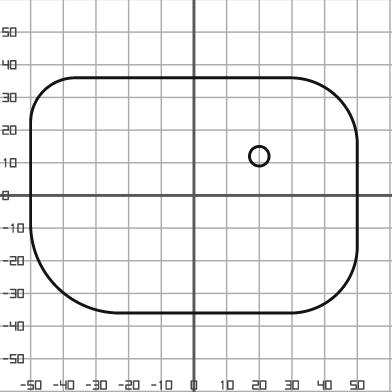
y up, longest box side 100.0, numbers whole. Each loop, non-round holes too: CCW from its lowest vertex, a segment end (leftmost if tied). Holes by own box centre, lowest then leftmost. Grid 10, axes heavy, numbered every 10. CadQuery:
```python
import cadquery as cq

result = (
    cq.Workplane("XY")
    .moveTo(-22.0, -36.0)
    .lineTo(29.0, -36.0)
    .threePointArc((44.0, -30.0), (50.0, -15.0))
    .lineTo(50.0, 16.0)
    .threePointArc((44.0, 30.0), (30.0, 36.0))
    .lineTo(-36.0, 36.0)
    .threePointArc((-46.0, 32.0), (-50.0, 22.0))
    .lineTo(-50.0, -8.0)
    .threePointArc((-42.0, -28.0), (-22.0, -36.0))
    .close()
    .moveTo(20.0, 12.0)
    .circle(3.0)
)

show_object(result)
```